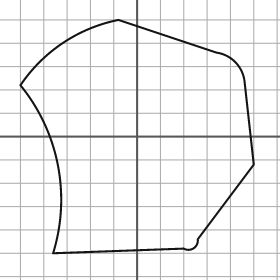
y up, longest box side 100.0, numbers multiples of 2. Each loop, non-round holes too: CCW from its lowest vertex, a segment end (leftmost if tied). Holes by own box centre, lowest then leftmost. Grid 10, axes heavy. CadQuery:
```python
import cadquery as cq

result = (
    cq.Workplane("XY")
    .moveTo(-36.0, -50.0)
    .lineTo(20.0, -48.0)
    .threePointArc((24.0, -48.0), (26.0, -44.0))
    .lineTo(50.0, -12.0)
    .lineTo(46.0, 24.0)
    .threePointArc((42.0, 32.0), (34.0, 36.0))
    .lineTo(-8.0, 50.0)
    .threePointArc((-32.0, 40.0), (-50.0, 22.0))
    .threePointArc((-34.0, -12.0), (-36.0, -50.0))
    .close()
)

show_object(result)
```